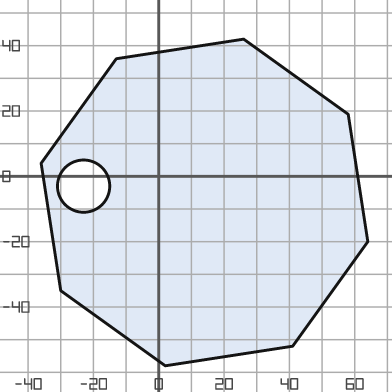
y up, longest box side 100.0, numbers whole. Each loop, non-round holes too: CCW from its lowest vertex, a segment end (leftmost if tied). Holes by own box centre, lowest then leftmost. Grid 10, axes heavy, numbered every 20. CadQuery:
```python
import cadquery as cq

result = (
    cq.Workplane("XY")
    .moveTo(2.0, -58.0)
    .lineTo(41.0, -52.0)
    .lineTo(64.0, -20.0)
    .lineTo(58.0, 19.0)
    .lineTo(26.0, 42.0)
    .lineTo(-13.0, 36.0)
    .lineTo(-36.0, 4.0)
    .lineTo(-30.0, -35.0)
    .close()
    .moveTo(-23.0, -3.0)
    .circle(8.0)
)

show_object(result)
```